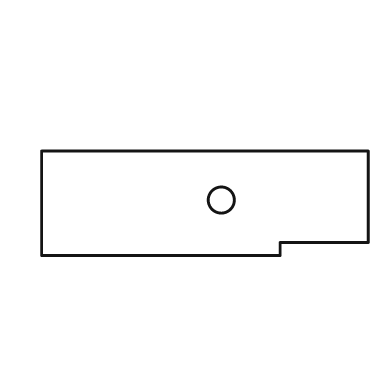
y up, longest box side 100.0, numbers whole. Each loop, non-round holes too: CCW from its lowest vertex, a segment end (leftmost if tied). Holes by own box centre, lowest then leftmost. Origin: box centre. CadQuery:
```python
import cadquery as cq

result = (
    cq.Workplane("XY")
    .moveTo(-50.0, -16.0)
    .lineTo(23.0, -16.0)
    .lineTo(23.0, -12.0)
    .lineTo(50.0, -12.0)
    .lineTo(50.0, 16.0)
    .lineTo(-50.0, 16.0)
    .close()
    .moveTo(5.0, 1.0)
    .circle(4.0)
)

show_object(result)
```